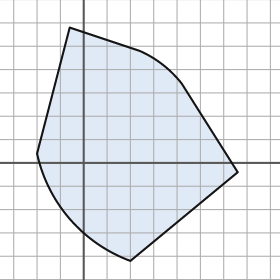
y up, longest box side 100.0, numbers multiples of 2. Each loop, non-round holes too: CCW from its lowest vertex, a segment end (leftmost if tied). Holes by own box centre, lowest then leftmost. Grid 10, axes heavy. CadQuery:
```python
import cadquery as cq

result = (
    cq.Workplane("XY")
    .moveTo(20.0, -42.0)
    .lineTo(66.0, -4.0)
    .lineTo(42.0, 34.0)
    .threePointArc((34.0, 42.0), (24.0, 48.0))
    .lineTo(-6.0, 58.0)
    .lineTo(-20.0, 4.0)
    .threePointArc((-6.0, -24.0), (20.0, -42.0))
    .close()
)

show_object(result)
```